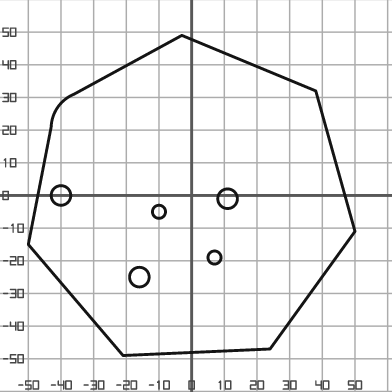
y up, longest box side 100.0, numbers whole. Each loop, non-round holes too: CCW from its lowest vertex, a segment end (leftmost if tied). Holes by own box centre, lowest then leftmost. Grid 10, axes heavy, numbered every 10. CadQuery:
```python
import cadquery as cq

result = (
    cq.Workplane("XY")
    .moveTo(-21.0, -49.0)
    .lineTo(24.0, -47.0)
    .lineTo(50.0, -11.0)
    .lineTo(38.0, 32.0)
    .lineTo(-3.0, 49.0)
    .lineTo(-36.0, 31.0)
    .threePointArc((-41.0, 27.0), (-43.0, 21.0))
    .lineTo(-50.0, -15.0)
    .close()
    .moveTo(-16.0, -25.0)
    .circle(3.0)
    .moveTo(7.0, -19.0)
    .circle(2.0)
    .moveTo(-10.0, -5.0)
    .circle(2.0)
    .moveTo(11.0, -1.0)
    .circle(3.0)
    .moveTo(-40.0, 0.0)
    .circle(3.0)
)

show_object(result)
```